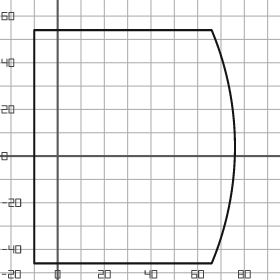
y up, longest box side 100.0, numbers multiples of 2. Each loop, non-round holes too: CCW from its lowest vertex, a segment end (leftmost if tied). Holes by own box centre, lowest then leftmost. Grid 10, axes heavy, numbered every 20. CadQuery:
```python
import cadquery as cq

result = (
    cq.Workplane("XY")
    .moveTo(-10.0, -46.0)
    .lineTo(66.0, -46.0)
    .threePointArc((76.0, 4.0), (66.0, 54.0))
    .lineTo(-10.0, 54.0)
    .close()
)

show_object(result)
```